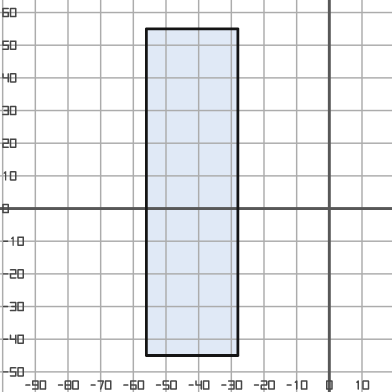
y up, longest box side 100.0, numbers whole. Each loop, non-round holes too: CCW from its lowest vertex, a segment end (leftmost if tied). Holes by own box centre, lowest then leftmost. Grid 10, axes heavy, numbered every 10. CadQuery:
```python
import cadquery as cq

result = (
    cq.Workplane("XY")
    .moveTo(-56.0, -45.0)
    .lineTo(-28.0, -45.0)
    .lineTo(-28.0, 55.0)
    .lineTo(-56.0, 55.0)
    .close()
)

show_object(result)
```